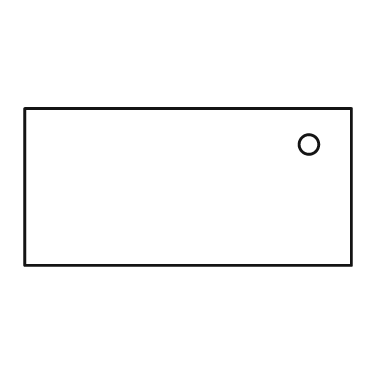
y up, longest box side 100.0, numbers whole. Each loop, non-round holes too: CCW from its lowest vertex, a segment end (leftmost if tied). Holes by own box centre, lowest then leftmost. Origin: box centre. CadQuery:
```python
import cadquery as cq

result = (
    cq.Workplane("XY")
    .moveTo(-50.0, -24.0)
    .lineTo(50.0, -24.0)
    .lineTo(50.0, 24.0)
    .lineTo(-50.0, 24.0)
    .close()
    .moveTo(37.0, 13.0)
    .circle(3.0)
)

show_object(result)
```